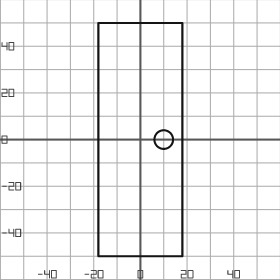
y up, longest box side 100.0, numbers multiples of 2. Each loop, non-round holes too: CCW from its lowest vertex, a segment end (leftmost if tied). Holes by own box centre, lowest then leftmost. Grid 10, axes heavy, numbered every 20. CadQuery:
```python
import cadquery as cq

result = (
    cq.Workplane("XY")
    .moveTo(-18.0, -50.0)
    .lineTo(18.0, -50.0)
    .lineTo(18.0, 50.0)
    .lineTo(-18.0, 50.0)
    .close()
    .moveTo(10.0, 0.0)
    .circle(4.0)
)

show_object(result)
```